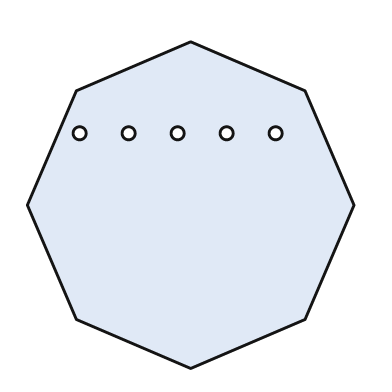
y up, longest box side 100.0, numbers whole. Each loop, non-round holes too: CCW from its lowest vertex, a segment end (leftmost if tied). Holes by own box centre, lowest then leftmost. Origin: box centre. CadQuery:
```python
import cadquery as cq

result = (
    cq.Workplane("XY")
    .moveTo(0.0, -50.0)
    .lineTo(35.0, -35.0)
    .lineTo(50.0, 0.0)
    .lineTo(35.0, 35.0)
    .lineTo(0.0, 50.0)
    .lineTo(-35.0, 35.0)
    .lineTo(-50.0, 0.0)
    .lineTo(-35.0, -35.0)
    .close()
    .moveTo(-34.0, 22.0)
    .circle(2.0)
    .moveTo(-19.0, 22.0)
    .circle(2.0)
    .moveTo(-4.0, 22.0)
    .circle(2.0)
    .moveTo(11.0, 22.0)
    .circle(2.0)
    .moveTo(26.0, 22.0)
    .circle(2.0)
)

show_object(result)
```